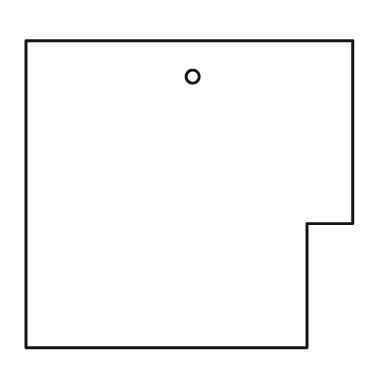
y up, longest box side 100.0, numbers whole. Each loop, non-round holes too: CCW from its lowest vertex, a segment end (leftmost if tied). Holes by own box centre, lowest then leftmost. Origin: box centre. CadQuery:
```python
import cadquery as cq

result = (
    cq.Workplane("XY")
    .moveTo(-50.0, -47.0)
    .lineTo(36.0, -47.0)
    .lineTo(36.0, -9.0)
    .lineTo(50.0, -9.0)
    .lineTo(50.0, 47.0)
    .lineTo(-50.0, 47.0)
    .close()
    .moveTo(1.0, 36.0)
    .circle(2.0)
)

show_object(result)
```